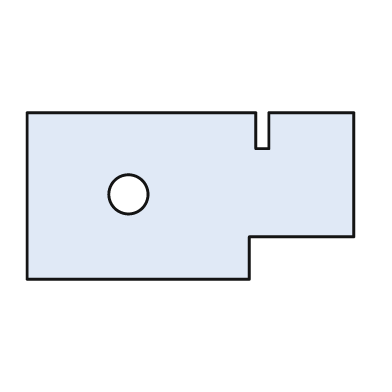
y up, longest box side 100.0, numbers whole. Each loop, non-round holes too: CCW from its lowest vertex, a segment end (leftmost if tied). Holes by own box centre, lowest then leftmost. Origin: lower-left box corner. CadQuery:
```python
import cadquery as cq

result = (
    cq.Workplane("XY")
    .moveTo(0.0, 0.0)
    .lineTo(68.0, 0.0)
    .lineTo(68.0, 13.0)
    .lineTo(100.0, 13.0)
    .lineTo(100.0, 51.0)
    .lineTo(74.0, 51.0)
    .lineTo(74.0, 40.0)
    .lineTo(70.0, 40.0)
    .lineTo(70.0, 51.0)
    .lineTo(0.0, 51.0)
    .close()
    .moveTo(31.0, 26.0)
    .circle(6.0)
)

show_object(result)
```